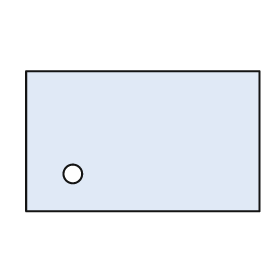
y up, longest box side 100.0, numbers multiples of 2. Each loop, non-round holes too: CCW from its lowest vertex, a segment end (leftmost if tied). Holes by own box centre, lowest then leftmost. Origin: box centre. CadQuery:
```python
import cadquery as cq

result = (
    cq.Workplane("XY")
    .moveTo(-50.0, -30.0)
    .lineTo(50.0, -30.0)
    .lineTo(50.0, 30.0)
    .lineTo(-50.0, 30.0)
    .close()
    .moveTo(-30.0, -14.0)
    .circle(4.0)
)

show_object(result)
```